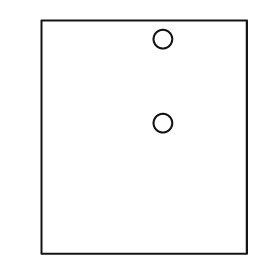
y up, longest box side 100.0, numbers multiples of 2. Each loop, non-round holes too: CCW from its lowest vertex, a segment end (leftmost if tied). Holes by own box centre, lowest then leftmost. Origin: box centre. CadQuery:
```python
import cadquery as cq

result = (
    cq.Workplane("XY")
    .moveTo(-44.0, -50.0)
    .lineTo(44.0, -50.0)
    .lineTo(44.0, 50.0)
    .lineTo(-44.0, 50.0)
    .close()
    .moveTo(8.0, 6.0)
    .circle(4.0)
    .moveTo(8.0, 42.0)
    .circle(4.0)
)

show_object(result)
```